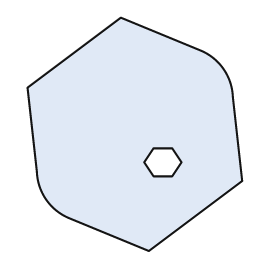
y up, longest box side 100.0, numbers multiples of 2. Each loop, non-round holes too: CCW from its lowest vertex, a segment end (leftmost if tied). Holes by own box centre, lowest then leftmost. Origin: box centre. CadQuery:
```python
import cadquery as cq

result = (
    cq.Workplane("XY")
    .moveTo(6.0, -50.0)
    .lineTo(46.0, -20.0)
    .lineTo(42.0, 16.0)
    .threePointArc((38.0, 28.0), (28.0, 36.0))
    .lineTo(-6.0, 50.0)
    .lineTo(-46.0, 20.0)
    .lineTo(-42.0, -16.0)
    .threePointArc((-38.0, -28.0), (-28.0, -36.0))
    .close()
    .moveTo(8.0, -18.0)
    .lineTo(16.0, -18.0)
    .lineTo(20.0, -12.0)
    .lineTo(16.0, -6.0)
    .lineTo(8.0, -6.0)
    .lineTo(4.0, -12.0)
    .close()
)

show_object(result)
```